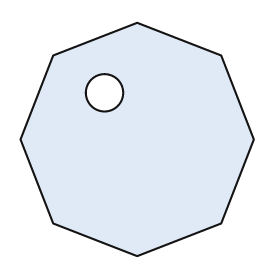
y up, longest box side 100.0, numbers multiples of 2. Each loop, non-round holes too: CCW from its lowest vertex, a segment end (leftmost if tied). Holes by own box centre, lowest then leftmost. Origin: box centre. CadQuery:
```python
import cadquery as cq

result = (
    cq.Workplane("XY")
    .moveTo(0.0, -50.0)
    .lineTo(36.0, -36.0)
    .lineTo(50.0, 0.0)
    .lineTo(36.0, 36.0)
    .lineTo(0.0, 50.0)
    .lineTo(-36.0, 36.0)
    .lineTo(-50.0, 0.0)
    .lineTo(-36.0, -36.0)
    .close()
    .moveTo(-14.0, 20.0)
    .circle(8.0)
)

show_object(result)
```